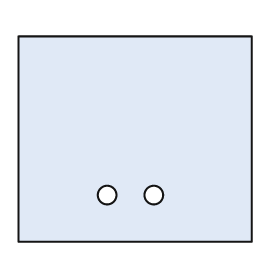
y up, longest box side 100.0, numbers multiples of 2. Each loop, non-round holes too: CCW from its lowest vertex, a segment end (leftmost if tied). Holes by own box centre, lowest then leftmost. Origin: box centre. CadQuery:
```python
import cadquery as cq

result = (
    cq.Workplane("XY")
    .moveTo(-50.0, -44.0)
    .lineTo(50.0, -44.0)
    .lineTo(50.0, 44.0)
    .lineTo(-50.0, 44.0)
    .close()
    .moveTo(-12.0, -24.0)
    .circle(4.0)
    .moveTo(8.0, -24.0)
    .circle(4.0)
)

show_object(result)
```